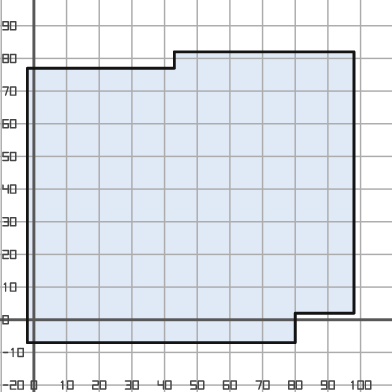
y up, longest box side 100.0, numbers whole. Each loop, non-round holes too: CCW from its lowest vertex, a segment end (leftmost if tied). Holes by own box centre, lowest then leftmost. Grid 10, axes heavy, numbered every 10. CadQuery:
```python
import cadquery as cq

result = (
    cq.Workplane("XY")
    .moveTo(-2.0, -7.0)
    .lineTo(80.0, -7.0)
    .lineTo(80.0, 2.0)
    .lineTo(98.0, 2.0)
    .lineTo(98.0, 82.0)
    .lineTo(43.0, 82.0)
    .lineTo(43.0, 77.0)
    .lineTo(-2.0, 77.0)
    .close()
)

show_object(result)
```